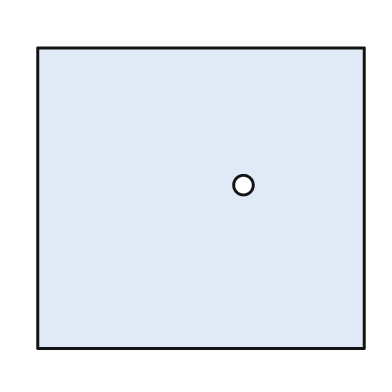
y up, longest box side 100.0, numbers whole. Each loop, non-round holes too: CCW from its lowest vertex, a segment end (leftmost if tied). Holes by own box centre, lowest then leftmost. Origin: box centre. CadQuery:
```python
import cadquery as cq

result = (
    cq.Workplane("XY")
    .moveTo(-50.0, -46.0)
    .lineTo(50.0, -46.0)
    .lineTo(50.0, 46.0)
    .lineTo(-50.0, 46.0)
    .close()
    .moveTo(13.0, 4.0)
    .circle(3.0)
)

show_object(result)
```